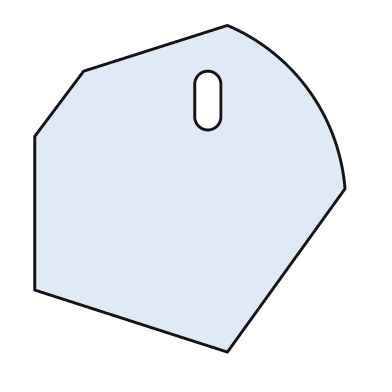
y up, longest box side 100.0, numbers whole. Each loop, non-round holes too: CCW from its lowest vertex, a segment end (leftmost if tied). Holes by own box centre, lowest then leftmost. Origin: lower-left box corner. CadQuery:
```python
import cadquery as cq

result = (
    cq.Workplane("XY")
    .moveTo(59.0, 0.0)
    .lineTo(95.0, 50.0)
    .threePointArc((84.0, 80.0), (59.0, 100.0))
    .lineTo(15.0, 86.0)
    .lineTo(0.0, 66.0)
    .lineTo(0.0, 19.0)
    .close()
    .moveTo(49.0, 72.0)
    .threePointArc((53.0, 68.0), (57.0, 72.0))
    .lineTo(57.0, 82.0)
    .threePointArc((53.0, 86.0), (49.0, 82.0))
    .close()
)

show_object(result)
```